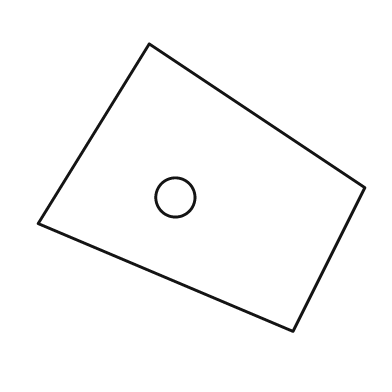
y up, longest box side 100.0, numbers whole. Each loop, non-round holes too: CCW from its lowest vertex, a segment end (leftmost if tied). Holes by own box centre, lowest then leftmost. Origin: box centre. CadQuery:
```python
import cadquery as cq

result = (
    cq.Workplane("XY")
    .moveTo(28.0, -44.0)
    .lineTo(50.0, 0.0)
    .lineTo(-16.0, 44.0)
    .lineTo(-50.0, -11.0)
    .close()
    .moveTo(-8.0, -3.0)
    .circle(6.0)
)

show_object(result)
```